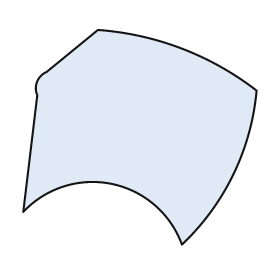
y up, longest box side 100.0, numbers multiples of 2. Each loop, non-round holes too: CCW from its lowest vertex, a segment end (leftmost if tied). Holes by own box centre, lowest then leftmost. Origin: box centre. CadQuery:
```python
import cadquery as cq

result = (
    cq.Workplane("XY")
    .moveTo(18.0, -46.0)
    .threePointArc((40.0, -16.0), (50.0, 20.0))
    .threePointArc((18.0, 38.0), (-18.0, 46.0))
    .lineTo(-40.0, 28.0)
    .threePointArc((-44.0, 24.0), (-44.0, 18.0))
    .lineTo(-50.0, -32.0)
    .threePointArc((-12.0, -20.0), (18.0, -46.0))
    .close()
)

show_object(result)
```